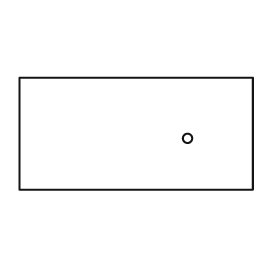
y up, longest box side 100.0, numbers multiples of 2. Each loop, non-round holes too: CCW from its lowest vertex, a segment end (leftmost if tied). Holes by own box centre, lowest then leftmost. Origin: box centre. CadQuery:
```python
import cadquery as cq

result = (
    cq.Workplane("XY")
    .moveTo(-50.0, -24.0)
    .lineTo(50.0, -24.0)
    .lineTo(50.0, 24.0)
    .lineTo(-50.0, 24.0)
    .close()
    .moveTo(22.0, -2.0)
    .circle(2.0)
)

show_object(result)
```